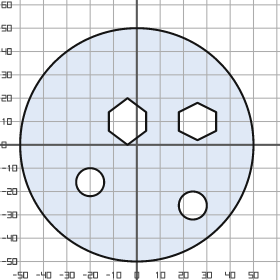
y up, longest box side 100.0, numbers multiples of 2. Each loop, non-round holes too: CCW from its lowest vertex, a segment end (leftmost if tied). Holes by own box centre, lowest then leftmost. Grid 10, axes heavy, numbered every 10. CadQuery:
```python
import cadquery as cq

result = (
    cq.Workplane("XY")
    .moveTo(0.0, 0.0)
    .circle(50.0)
    .moveTo(24.0, -26.0)
    .circle(6.0)
    .moveTo(-20.0, -16.0)
    .circle(6.0)
    .moveTo(-4.0, 0.0)
    .lineTo(4.0, 6.0)
    .lineTo(4.0, 14.0)
    .lineTo(-4.0, 20.0)
    .lineTo(-12.0, 14.0)
    .lineTo(-12.0, 6.0)
    .close()
    .moveTo(26.0, 2.0)
    .lineTo(34.0, 6.0)
    .lineTo(34.0, 14.0)
    .lineTo(26.0, 18.0)
    .lineTo(18.0, 14.0)
    .lineTo(18.0, 6.0)
    .close()
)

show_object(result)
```